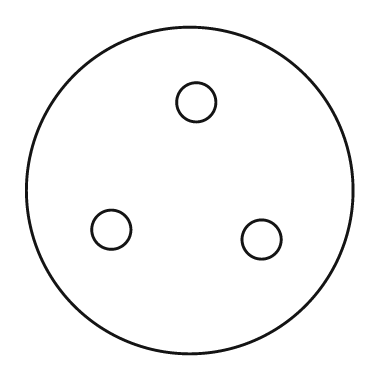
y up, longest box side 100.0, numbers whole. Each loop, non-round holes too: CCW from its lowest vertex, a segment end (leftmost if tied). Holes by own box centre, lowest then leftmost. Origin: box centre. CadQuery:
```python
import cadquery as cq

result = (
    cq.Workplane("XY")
    .moveTo(0.0, 0.0)
    .circle(50.0)
    .moveTo(22.0, -15.0)
    .circle(6.0)
    .moveTo(-24.0, -12.0)
    .circle(6.0)
    .moveTo(2.0, 27.0)
    .circle(6.0)
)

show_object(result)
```